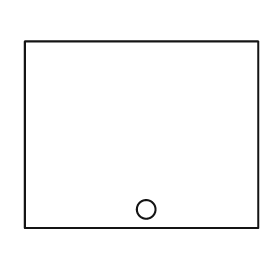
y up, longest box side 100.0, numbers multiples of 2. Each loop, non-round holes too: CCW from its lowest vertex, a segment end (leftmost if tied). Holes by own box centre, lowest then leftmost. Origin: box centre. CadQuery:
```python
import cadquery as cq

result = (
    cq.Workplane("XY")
    .moveTo(-50.0, -40.0)
    .lineTo(50.0, -40.0)
    .lineTo(50.0, 40.0)
    .lineTo(-50.0, 40.0)
    .close()
    .moveTo(2.0, -32.0)
    .circle(4.0)
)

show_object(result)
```